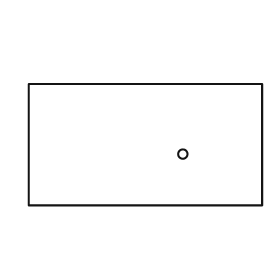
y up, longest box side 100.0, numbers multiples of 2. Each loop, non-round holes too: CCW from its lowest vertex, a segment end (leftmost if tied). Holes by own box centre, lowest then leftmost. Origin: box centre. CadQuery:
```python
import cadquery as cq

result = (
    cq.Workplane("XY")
    .moveTo(-50.0, -26.0)
    .lineTo(50.0, -26.0)
    .lineTo(50.0, 26.0)
    .lineTo(-50.0, 26.0)
    .close()
    .moveTo(16.0, -4.0)
    .circle(2.0)
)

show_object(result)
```